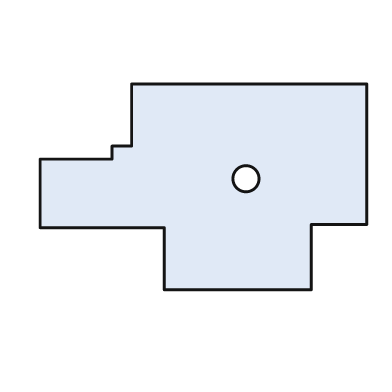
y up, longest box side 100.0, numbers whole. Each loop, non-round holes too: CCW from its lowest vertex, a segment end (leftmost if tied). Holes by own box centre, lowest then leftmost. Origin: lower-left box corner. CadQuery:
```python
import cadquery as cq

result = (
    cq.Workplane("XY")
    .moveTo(38.0, 0.0)
    .lineTo(83.0, 0.0)
    .lineTo(83.0, 20.0)
    .lineTo(100.0, 20.0)
    .lineTo(100.0, 63.0)
    .lineTo(28.0, 63.0)
    .lineTo(28.0, 44.0)
    .lineTo(22.0, 44.0)
    .lineTo(22.0, 40.0)
    .lineTo(0.0, 40.0)
    .lineTo(0.0, 19.0)
    .lineTo(38.0, 19.0)
    .close()
    .moveTo(63.0, 34.0)
    .circle(4.0)
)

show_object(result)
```